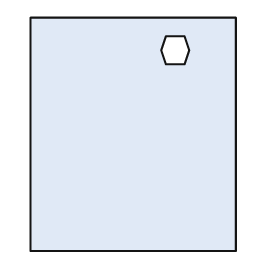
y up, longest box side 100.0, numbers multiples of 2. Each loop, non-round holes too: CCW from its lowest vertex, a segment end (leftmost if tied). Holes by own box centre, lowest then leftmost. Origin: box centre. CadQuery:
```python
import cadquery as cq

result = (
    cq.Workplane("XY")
    .moveTo(-44.0, -50.0)
    .lineTo(44.0, -50.0)
    .lineTo(44.0, 50.0)
    .lineTo(-44.0, 50.0)
    .close()
    .moveTo(14.0, 30.0)
    .lineTo(22.0, 30.0)
    .lineTo(24.0, 36.0)
    .lineTo(22.0, 42.0)
    .lineTo(14.0, 42.0)
    .lineTo(12.0, 36.0)
    .close()
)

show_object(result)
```